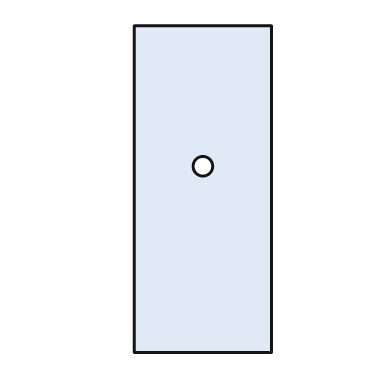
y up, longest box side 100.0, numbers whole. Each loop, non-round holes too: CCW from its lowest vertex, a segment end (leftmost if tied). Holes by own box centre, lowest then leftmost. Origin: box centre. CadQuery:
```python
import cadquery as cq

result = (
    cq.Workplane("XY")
    .moveTo(-21.0, -50.0)
    .lineTo(21.0, -50.0)
    .lineTo(21.0, 50.0)
    .lineTo(-21.0, 50.0)
    .close()
    .moveTo(0.0, 7.0)
    .circle(3.0)
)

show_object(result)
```